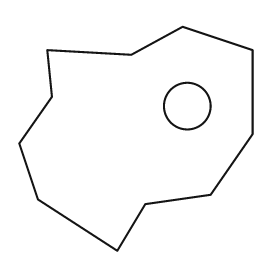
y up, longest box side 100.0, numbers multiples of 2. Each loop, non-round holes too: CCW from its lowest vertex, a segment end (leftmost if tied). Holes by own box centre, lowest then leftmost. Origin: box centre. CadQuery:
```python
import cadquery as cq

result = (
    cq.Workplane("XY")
    .moveTo(-8.0, -48.0)
    .lineTo(4.0, -28.0)
    .lineTo(32.0, -24.0)
    .lineTo(50.0, 2.0)
    .lineTo(50.0, 38.0)
    .lineTo(20.0, 48.0)
    .lineTo(-2.0, 36.0)
    .lineTo(-38.0, 38.0)
    .lineTo(-36.0, 18.0)
    .lineTo(-50.0, -2.0)
    .lineTo(-42.0, -26.0)
    .close()
    .moveTo(22.0, 14.0)
    .circle(10.0)
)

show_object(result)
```